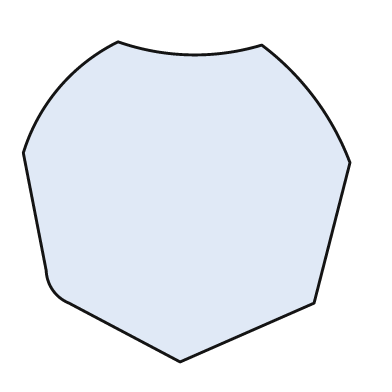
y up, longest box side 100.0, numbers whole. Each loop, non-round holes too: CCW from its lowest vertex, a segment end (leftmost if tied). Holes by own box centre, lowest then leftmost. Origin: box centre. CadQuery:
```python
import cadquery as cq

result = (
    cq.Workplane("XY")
    .moveTo(-2.0, -49.0)
    .lineTo(39.0, -31.0)
    .lineTo(50.0, 12.0)
    .threePointArc((39.0, 32.0), (23.0, 48.0))
    .threePointArc((1.0, 45.0), (-21.0, 49.0))
    .threePointArc((-39.0, 35.0), (-50.0, 15.0))
    .lineTo(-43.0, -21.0)
    .threePointArc((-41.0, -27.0), (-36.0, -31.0))
    .close()
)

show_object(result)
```